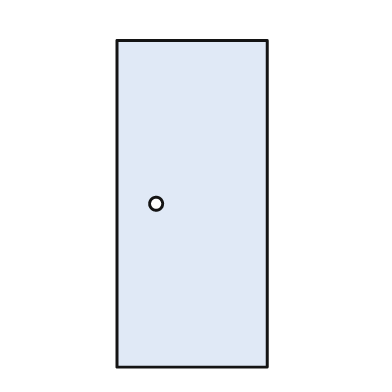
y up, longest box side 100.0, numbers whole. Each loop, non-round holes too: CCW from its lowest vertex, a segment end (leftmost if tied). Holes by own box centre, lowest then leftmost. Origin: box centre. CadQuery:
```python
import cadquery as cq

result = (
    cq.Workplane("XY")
    .moveTo(-23.0, -50.0)
    .lineTo(23.0, -50.0)
    .lineTo(23.0, 50.0)
    .lineTo(-23.0, 50.0)
    .close()
    .moveTo(-11.0, 0.0)
    .circle(2.0)
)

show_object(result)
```